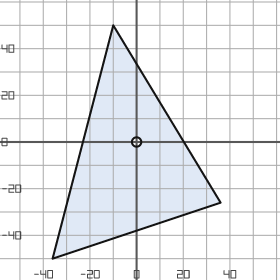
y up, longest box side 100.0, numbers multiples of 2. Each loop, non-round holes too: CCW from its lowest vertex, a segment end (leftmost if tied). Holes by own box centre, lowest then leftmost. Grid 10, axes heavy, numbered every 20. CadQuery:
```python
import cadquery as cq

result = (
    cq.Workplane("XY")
    .moveTo(-36.0, -50.0)
    .lineTo(36.0, -26.0)
    .lineTo(-10.0, 50.0)
    .close()
    .moveTo(0.0, 0.0)
    .circle(2.0)
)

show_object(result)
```